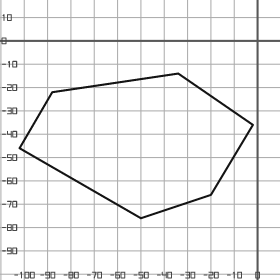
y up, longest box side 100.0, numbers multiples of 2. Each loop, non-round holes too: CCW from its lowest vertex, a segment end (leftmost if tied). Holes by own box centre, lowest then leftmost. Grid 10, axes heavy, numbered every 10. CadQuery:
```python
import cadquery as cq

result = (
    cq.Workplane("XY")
    .moveTo(-50.0, -76.0)
    .lineTo(-20.0, -66.0)
    .lineTo(-2.0, -36.0)
    .lineTo(-34.0, -14.0)
    .lineTo(-88.0, -22.0)
    .lineTo(-102.0, -46.0)
    .close()
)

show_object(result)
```